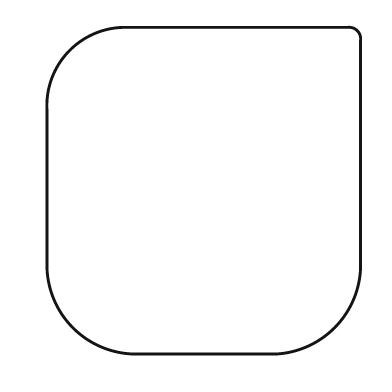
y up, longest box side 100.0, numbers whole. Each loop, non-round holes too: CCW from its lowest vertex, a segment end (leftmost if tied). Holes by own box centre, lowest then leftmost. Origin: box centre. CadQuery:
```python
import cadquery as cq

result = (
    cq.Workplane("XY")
    .moveTo(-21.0, -50.0)
    .lineTo(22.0, -50.0)
    .threePointArc((40.0, -42.0), (48.0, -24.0))
    .lineTo(48.0, 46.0)
    .threePointArc((47.0, 49.0), (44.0, 50.0))
    .lineTo(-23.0, 50.0)
    .threePointArc((-41.0, 43.0), (-48.0, 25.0))
    .lineTo(-48.0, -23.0)
    .threePointArc((-40.0, -42.0), (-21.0, -50.0))
    .close()
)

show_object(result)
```